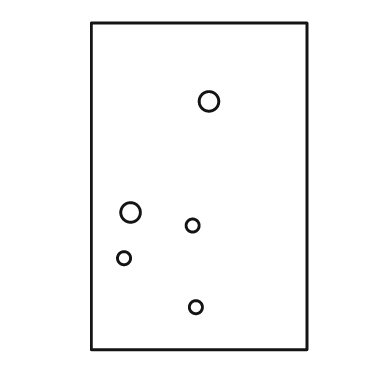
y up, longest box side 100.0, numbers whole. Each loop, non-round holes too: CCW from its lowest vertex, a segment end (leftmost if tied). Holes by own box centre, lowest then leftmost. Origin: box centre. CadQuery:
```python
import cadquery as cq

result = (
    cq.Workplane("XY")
    .moveTo(-33.0, -50.0)
    .lineTo(33.0, -50.0)
    .lineTo(33.0, 50.0)
    .lineTo(-33.0, 50.0)
    .close()
    .moveTo(-1.0, -37.0)
    .circle(2.0)
    .moveTo(-23.0, -22.0)
    .circle(2.0)
    .moveTo(-2.0, -12.0)
    .circle(2.0)
    .moveTo(-21.0, -8.0)
    .circle(3.0)
    .moveTo(3.0, 26.0)
    .circle(3.0)
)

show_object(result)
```